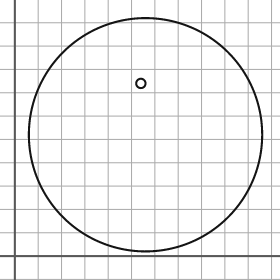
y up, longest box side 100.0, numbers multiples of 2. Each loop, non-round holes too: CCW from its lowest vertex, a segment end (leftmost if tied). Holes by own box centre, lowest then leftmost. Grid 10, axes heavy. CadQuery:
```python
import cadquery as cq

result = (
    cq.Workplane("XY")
    .moveTo(56.0, 52.0)
    .circle(50.0)
    .moveTo(54.0, 74.0)
    .circle(2.0)
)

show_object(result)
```